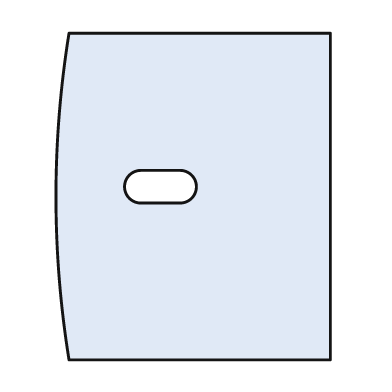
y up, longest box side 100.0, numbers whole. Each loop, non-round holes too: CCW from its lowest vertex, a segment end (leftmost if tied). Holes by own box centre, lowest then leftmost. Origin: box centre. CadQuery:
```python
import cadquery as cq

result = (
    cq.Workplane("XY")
    .moveTo(-38.0, -50.0)
    .lineTo(42.0, -50.0)
    .lineTo(42.0, 50.0)
    .lineTo(-38.0, 50.0)
    .threePointArc((-42.0, 0.0), (-38.0, -50.0))
    .close()
    .moveTo(-16.0, -2.0)
    .lineTo(-4.0, -2.0)
    .threePointArc((1.0, 3.0), (-4.0, 8.0))
    .lineTo(-16.0, 8.0)
    .threePointArc((-21.0, 3.0), (-16.0, -2.0))
    .close()
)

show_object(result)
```